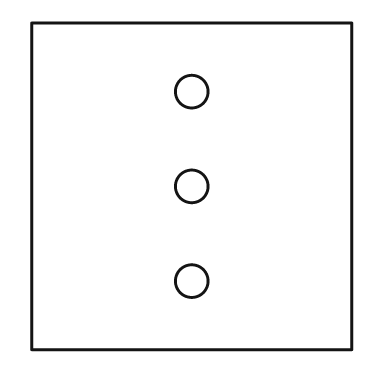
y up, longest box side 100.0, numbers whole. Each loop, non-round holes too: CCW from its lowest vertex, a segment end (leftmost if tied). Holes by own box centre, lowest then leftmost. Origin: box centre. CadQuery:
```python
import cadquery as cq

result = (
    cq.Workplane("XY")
    .moveTo(-49.0, -50.0)
    .lineTo(49.0, -50.0)
    .lineTo(49.0, 50.0)
    .lineTo(-49.0, 50.0)
    .close()
    .moveTo(0.0, -29.0)
    .circle(5.0)
    .moveTo(0.0, 0.0)
    .circle(5.0)
    .moveTo(0.0, 29.0)
    .circle(5.0)
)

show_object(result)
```